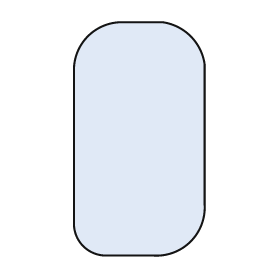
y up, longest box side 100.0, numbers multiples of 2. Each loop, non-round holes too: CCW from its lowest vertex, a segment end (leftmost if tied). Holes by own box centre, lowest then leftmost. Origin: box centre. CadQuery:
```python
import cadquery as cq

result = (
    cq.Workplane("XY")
    .moveTo(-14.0, -50.0)
    .lineTo(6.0, -50.0)
    .threePointArc((22.0, -44.0), (28.0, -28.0))
    .lineTo(28.0, 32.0)
    .threePointArc((22.0, 44.0), (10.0, 50.0))
    .lineTo(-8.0, 50.0)
    .threePointArc((-22.0, 44.0), (-28.0, 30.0))
    .lineTo(-28.0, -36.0)
    .threePointArc((-24.0, -46.0), (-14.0, -50.0))
    .close()
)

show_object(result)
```